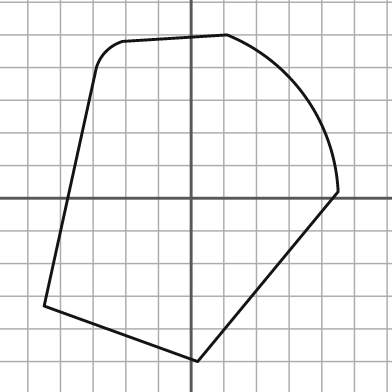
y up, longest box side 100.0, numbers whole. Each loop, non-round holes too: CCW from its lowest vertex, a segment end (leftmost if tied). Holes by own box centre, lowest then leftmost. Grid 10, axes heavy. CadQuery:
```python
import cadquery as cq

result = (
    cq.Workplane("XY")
    .moveTo(2.0, -50.0)
    .lineTo(45.0, 2.0)
    .threePointArc((35.0, 31.0), (11.0, 50.0))
    .lineTo(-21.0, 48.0)
    .threePointArc((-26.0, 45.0), (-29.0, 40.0))
    .lineTo(-45.0, -33.0)
    .close()
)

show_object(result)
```